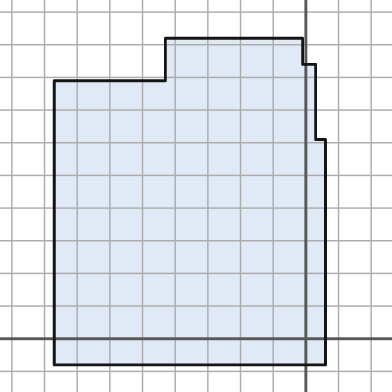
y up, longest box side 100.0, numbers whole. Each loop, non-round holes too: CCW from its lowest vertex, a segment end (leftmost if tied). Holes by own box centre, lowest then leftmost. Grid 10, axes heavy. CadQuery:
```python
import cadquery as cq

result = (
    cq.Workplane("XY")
    .moveTo(-77.0, -8.0)
    .lineTo(6.0, -8.0)
    .lineTo(6.0, 61.0)
    .lineTo(3.0, 61.0)
    .lineTo(3.0, 84.0)
    .lineTo(-1.0, 84.0)
    .lineTo(-1.0, 92.0)
    .lineTo(-43.0, 92.0)
    .lineTo(-43.0, 79.0)
    .lineTo(-77.0, 79.0)
    .close()
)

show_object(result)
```